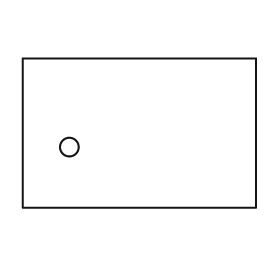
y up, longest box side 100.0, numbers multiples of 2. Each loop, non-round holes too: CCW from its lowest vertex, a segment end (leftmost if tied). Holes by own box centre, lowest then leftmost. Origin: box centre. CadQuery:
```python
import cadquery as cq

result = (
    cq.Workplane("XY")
    .moveTo(-50.0, -32.0)
    .lineTo(50.0, -32.0)
    .lineTo(50.0, 32.0)
    .lineTo(-50.0, 32.0)
    .close()
    .moveTo(-30.0, -6.0)
    .circle(4.0)
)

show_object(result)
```